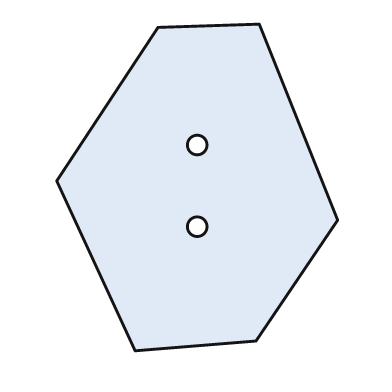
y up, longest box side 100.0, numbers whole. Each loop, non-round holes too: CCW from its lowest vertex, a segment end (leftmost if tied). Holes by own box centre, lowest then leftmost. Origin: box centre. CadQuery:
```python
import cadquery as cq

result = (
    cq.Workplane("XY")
    .moveTo(-19.0, -50.0)
    .lineTo(18.0, -47.0)
    .lineTo(43.0, -10.0)
    .lineTo(19.0, 50.0)
    .lineTo(-12.0, 49.0)
    .lineTo(-43.0, 2.0)
    .close()
    .moveTo(0.0, -12.0)
    .circle(3.0)
    .moveTo(0.0, 13.0)
    .circle(3.0)
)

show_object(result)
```